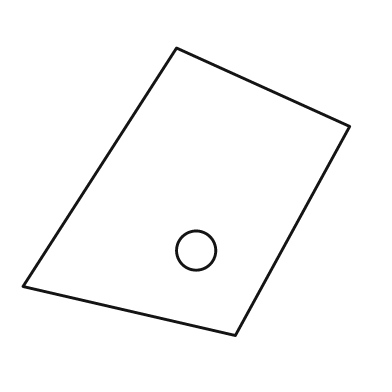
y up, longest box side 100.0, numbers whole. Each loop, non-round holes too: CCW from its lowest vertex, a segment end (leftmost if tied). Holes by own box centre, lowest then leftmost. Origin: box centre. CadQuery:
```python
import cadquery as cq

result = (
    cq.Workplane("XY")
    .moveTo(15.0, -44.0)
    .lineTo(50.0, 20.0)
    .lineTo(-3.0, 44.0)
    .lineTo(-50.0, -29.0)
    .close()
    .moveTo(3.0, -18.0)
    .circle(6.0)
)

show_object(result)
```